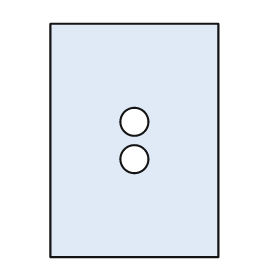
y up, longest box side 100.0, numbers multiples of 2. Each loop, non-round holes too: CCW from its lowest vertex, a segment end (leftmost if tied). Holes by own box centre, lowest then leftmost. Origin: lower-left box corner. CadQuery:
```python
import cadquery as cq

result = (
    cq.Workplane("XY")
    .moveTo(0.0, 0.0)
    .lineTo(72.0, 0.0)
    .lineTo(72.0, 100.0)
    .lineTo(0.0, 100.0)
    .close()
    .moveTo(36.0, 42.0)
    .circle(6.0)
    .moveTo(36.0, 58.0)
    .circle(6.0)
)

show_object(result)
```